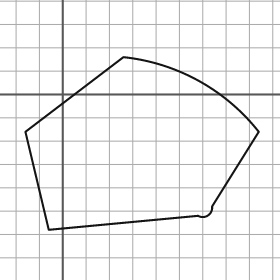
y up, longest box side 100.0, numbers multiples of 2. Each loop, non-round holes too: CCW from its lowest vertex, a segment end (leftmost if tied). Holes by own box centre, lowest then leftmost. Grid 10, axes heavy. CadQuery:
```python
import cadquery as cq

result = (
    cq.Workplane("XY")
    .moveTo(-6.0, -58.0)
    .lineTo(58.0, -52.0)
    .threePointArc((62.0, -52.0), (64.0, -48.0))
    .lineTo(84.0, -16.0)
    .threePointArc((58.0, 6.0), (26.0, 16.0))
    .lineTo(-16.0, -16.0)
    .close()
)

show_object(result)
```